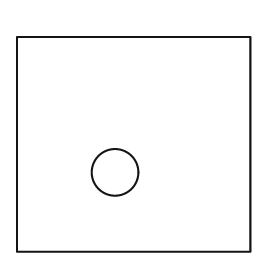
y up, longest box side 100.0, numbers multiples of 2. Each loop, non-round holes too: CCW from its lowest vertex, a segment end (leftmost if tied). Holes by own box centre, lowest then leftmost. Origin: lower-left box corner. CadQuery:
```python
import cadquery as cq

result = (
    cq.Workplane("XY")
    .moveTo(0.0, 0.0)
    .lineTo(100.0, 0.0)
    .lineTo(100.0, 92.0)
    .lineTo(0.0, 92.0)
    .close()
    .moveTo(42.0, 34.0)
    .circle(10.0)
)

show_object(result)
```